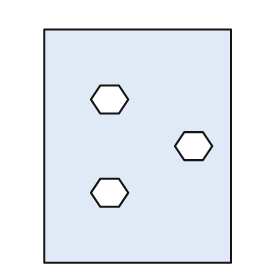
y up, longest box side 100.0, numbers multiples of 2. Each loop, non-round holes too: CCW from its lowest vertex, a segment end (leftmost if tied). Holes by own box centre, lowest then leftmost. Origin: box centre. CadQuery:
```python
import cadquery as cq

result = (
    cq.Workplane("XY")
    .moveTo(-40.0, -50.0)
    .lineTo(40.0, -50.0)
    .lineTo(40.0, 50.0)
    .lineTo(-40.0, 50.0)
    .close()
    .moveTo(-16.0, -26.0)
    .lineTo(-8.0, -26.0)
    .lineTo(-4.0, -20.0)
    .lineTo(-8.0, -14.0)
    .lineTo(-16.0, -14.0)
    .lineTo(-20.0, -20.0)
    .close()
    .moveTo(20.0, -6.0)
    .lineTo(28.0, -6.0)
    .lineTo(32.0, 0.0)
    .lineTo(28.0, 6.0)
    .lineTo(20.0, 6.0)
    .lineTo(16.0, 0.0)
    .close()
    .moveTo(-16.0, 14.0)
    .lineTo(-8.0, 14.0)
    .lineTo(-4.0, 20.0)
    .lineTo(-8.0, 26.0)
    .lineTo(-16.0, 26.0)
    .lineTo(-20.0, 20.0)
    .close()
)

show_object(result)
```